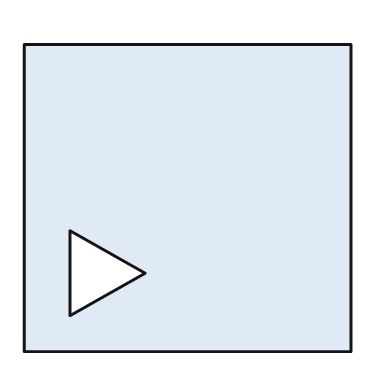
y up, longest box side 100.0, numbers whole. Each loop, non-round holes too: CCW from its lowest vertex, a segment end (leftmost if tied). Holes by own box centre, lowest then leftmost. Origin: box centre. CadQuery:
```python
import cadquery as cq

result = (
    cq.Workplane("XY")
    .moveTo(-50.0, -47.0)
    .lineTo(50.0, -47.0)
    .lineTo(50.0, 47.0)
    .lineTo(-50.0, 47.0)
    .close()
    .moveTo(-36.0, -36.0)
    .lineTo(-13.0, -23.0)
    .lineTo(-36.0, -10.0)
    .close()
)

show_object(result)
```